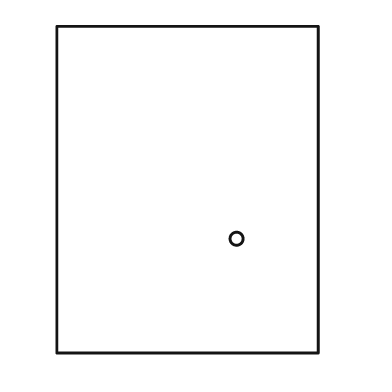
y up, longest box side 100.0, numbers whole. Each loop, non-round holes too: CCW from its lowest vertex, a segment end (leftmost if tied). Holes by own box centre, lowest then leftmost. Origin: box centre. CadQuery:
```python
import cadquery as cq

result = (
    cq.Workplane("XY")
    .moveTo(-40.0, -50.0)
    .lineTo(40.0, -50.0)
    .lineTo(40.0, 50.0)
    .lineTo(-40.0, 50.0)
    .close()
    .moveTo(15.0, -15.0)
    .circle(2.0)
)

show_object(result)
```